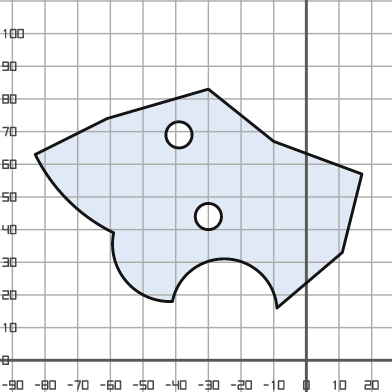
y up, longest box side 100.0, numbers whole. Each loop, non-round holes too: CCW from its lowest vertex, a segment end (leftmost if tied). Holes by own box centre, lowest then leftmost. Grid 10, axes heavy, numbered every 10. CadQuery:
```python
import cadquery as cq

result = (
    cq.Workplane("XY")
    .moveTo(-9.0, 16.0)
    .lineTo(11.0, 33.0)
    .lineTo(17.0, 57.0)
    .lineTo(-10.0, 67.0)
    .lineTo(-30.0, 83.0)
    .lineTo(-61.0, 74.0)
    .lineTo(-83.0, 63.0)
    .threePointArc((-73.0, 49.0), (-59.0, 39.0))
    .threePointArc((-55.0, 24.0), (-41.0, 18.0))
    .threePointArc((-24.0, 31.0), (-9.0, 16.0))
    .close()
    .moveTo(-30.0, 44.0)
    .circle(4.0)
    .moveTo(-39.0, 69.0)
    .circle(4.0)
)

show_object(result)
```